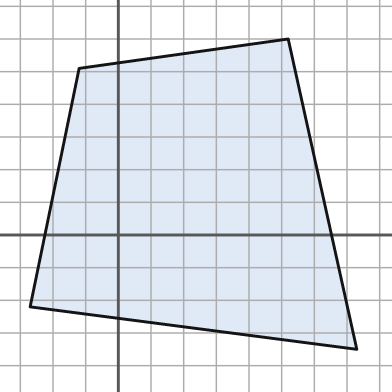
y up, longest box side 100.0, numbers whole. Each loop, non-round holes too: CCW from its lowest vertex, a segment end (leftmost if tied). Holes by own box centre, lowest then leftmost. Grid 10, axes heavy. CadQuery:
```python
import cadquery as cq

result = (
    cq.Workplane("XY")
    .moveTo(73.0, -35.0)
    .lineTo(52.0, 60.0)
    .lineTo(-12.0, 51.0)
    .lineTo(-27.0, -22.0)
    .close()
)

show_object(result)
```